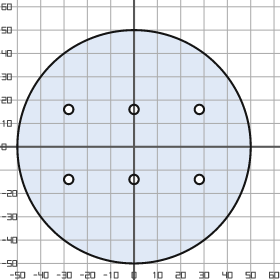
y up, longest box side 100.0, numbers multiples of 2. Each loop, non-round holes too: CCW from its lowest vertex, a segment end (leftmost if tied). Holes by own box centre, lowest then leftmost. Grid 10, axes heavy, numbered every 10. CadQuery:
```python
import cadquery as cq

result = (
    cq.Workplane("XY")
    .moveTo(0.0, 0.0)
    .circle(50.0)
    .moveTo(-28.0, -14.0)
    .circle(2.0)
    .moveTo(0.0, -14.0)
    .circle(2.0)
    .moveTo(28.0, -14.0)
    .circle(2.0)
    .moveTo(-28.0, 16.0)
    .circle(2.0)
    .moveTo(0.0, 16.0)
    .circle(2.0)
    .moveTo(28.0, 16.0)
    .circle(2.0)
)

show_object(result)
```